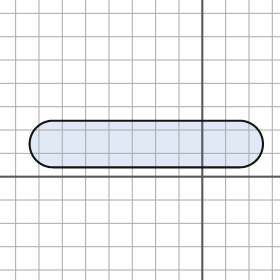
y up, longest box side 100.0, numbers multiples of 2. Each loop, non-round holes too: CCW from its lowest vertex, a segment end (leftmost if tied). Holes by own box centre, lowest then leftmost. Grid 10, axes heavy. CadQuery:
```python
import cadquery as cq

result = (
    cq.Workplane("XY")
    .moveTo(-64.0, 4.0)
    .lineTo(16.0, 4.0)
    .threePointArc((26.0, 14.0), (16.0, 24.0))
    .lineTo(-64.0, 24.0)
    .threePointArc((-74.0, 14.0), (-64.0, 4.0))
    .close()
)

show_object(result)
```